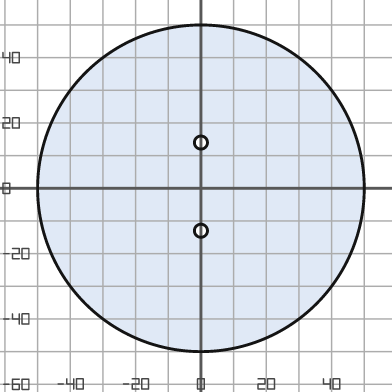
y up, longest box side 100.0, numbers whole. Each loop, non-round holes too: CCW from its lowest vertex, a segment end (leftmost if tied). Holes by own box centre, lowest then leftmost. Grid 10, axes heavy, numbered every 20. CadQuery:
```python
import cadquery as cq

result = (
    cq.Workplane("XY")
    .moveTo(0.0, 0.0)
    .circle(50.0)
    .moveTo(0.0, -13.0)
    .circle(2.0)
    .moveTo(0.0, 14.0)
    .circle(2.0)
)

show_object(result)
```